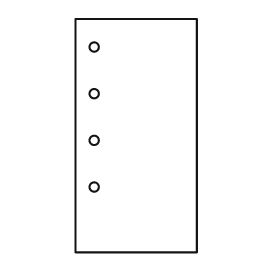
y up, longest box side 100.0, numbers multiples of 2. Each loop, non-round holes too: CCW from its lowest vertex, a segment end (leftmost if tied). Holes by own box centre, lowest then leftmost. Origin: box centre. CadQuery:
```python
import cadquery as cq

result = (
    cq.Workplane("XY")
    .moveTo(-26.0, -50.0)
    .lineTo(26.0, -50.0)
    .lineTo(26.0, 50.0)
    .lineTo(-26.0, 50.0)
    .close()
    .moveTo(-18.0, -22.0)
    .circle(2.0)
    .moveTo(-18.0, -2.0)
    .circle(2.0)
    .moveTo(-18.0, 18.0)
    .circle(2.0)
    .moveTo(-18.0, 38.0)
    .circle(2.0)
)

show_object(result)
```